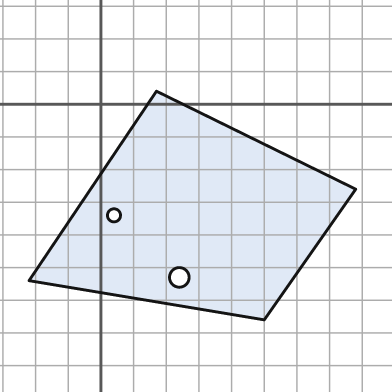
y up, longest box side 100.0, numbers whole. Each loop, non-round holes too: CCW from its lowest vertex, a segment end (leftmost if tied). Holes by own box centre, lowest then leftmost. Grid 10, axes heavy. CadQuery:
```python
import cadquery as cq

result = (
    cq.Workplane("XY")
    .moveTo(50.0, -66.0)
    .lineTo(78.0, -26.0)
    .lineTo(17.0, 4.0)
    .lineTo(-22.0, -54.0)
    .close()
    .moveTo(24.0, -53.0)
    .circle(3.0)
    .moveTo(4.0, -34.0)
    .circle(2.0)
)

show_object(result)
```